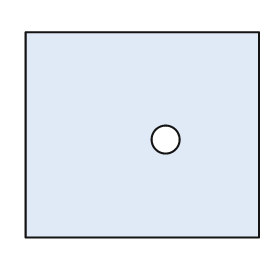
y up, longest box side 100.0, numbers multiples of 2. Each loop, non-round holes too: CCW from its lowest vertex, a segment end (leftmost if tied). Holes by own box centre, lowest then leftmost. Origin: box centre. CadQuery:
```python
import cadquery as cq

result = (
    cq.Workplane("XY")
    .moveTo(-50.0, -44.0)
    .lineTo(50.0, -44.0)
    .lineTo(50.0, 44.0)
    .lineTo(-50.0, 44.0)
    .close()
    .moveTo(10.0, -2.0)
    .circle(6.0)
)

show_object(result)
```